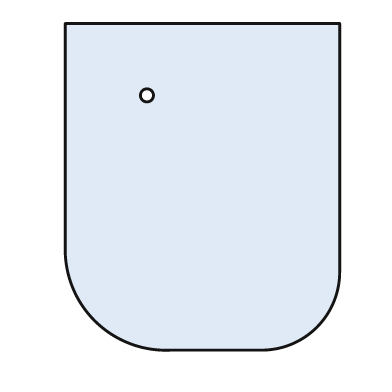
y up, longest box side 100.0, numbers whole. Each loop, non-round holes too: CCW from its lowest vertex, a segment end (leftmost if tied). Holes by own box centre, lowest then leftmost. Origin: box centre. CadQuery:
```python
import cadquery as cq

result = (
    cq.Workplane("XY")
    .moveTo(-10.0, -50.0)
    .lineTo(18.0, -50.0)
    .threePointArc((35.0, -43.0), (42.0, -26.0))
    .lineTo(42.0, 50.0)
    .lineTo(-42.0, 50.0)
    .lineTo(-42.0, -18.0)
    .threePointArc((-33.0, -41.0), (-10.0, -50.0))
    .close()
    .moveTo(-17.0, 28.0)
    .circle(2.0)
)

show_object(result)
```